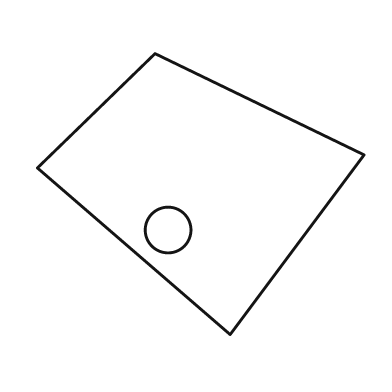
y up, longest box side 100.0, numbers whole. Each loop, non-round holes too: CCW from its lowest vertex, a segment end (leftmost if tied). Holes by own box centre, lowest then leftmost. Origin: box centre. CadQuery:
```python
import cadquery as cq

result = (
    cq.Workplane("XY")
    .moveTo(9.0, -43.0)
    .lineTo(50.0, 12.0)
    .lineTo(-14.0, 43.0)
    .lineTo(-50.0, 8.0)
    .close()
    .moveTo(-10.0, -11.0)
    .circle(7.0)
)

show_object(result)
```